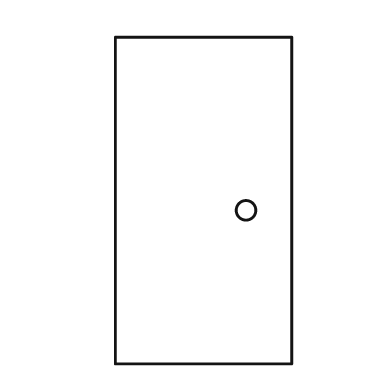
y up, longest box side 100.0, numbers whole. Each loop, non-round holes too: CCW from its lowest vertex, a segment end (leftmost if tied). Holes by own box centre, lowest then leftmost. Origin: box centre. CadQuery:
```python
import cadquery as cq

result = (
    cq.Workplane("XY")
    .moveTo(-27.0, -50.0)
    .lineTo(27.0, -50.0)
    .lineTo(27.0, 50.0)
    .lineTo(-27.0, 50.0)
    .close()
    .moveTo(13.0, -3.0)
    .circle(3.0)
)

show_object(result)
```